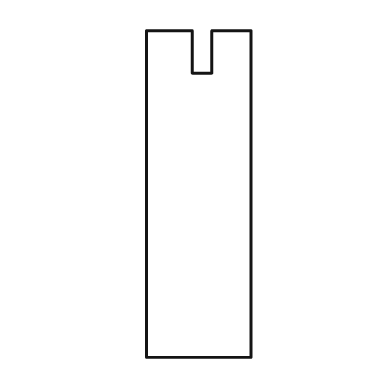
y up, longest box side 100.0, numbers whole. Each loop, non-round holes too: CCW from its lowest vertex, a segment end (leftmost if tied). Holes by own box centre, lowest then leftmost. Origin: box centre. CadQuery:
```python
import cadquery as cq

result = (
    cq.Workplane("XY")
    .moveTo(-16.0, -50.0)
    .lineTo(16.0, -50.0)
    .lineTo(16.0, 50.0)
    .lineTo(4.0, 50.0)
    .lineTo(4.0, 37.0)
    .lineTo(-2.0, 37.0)
    .lineTo(-2.0, 50.0)
    .lineTo(-16.0, 50.0)
    .close()
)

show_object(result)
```